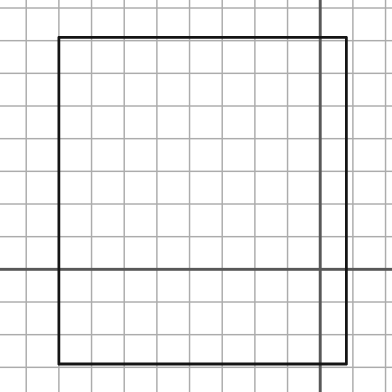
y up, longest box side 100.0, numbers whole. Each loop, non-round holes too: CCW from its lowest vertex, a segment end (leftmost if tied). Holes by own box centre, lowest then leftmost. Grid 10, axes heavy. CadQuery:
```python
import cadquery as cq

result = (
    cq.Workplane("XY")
    .moveTo(-80.0, -29.0)
    .lineTo(8.0, -29.0)
    .lineTo(8.0, 71.0)
    .lineTo(-80.0, 71.0)
    .close()
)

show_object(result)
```